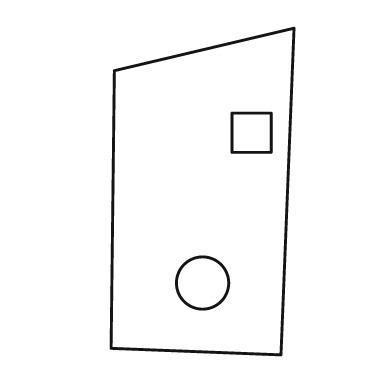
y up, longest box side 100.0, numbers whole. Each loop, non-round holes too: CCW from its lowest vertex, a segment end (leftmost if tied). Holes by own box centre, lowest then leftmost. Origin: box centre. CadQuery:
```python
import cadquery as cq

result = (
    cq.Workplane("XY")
    .moveTo(24.0, -50.0)
    .lineTo(28.0, 50.0)
    .lineTo(-27.0, 37.0)
    .lineTo(-28.0, -48.0)
    .close()
    .moveTo(0.0, -28.0)
    .circle(8.0)
    .moveTo(9.0, 12.0)
    .lineTo(21.0, 12.0)
    .lineTo(21.0, 24.0)
    .lineTo(9.0, 24.0)
    .close()
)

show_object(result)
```